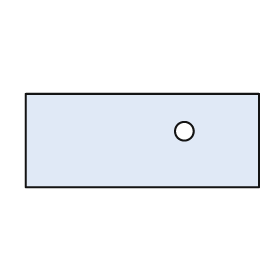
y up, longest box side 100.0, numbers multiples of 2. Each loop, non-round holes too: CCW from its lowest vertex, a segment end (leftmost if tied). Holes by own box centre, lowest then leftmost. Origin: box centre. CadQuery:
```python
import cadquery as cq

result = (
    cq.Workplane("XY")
    .moveTo(-50.0, -20.0)
    .lineTo(50.0, -20.0)
    .lineTo(50.0, 20.0)
    .lineTo(-50.0, 20.0)
    .close()
    .moveTo(18.0, 4.0)
    .circle(4.0)
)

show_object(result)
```